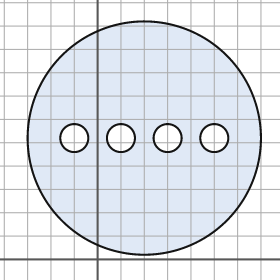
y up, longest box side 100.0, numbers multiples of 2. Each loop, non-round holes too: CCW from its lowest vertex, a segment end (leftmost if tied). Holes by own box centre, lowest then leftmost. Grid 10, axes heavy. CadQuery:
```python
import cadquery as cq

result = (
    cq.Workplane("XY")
    .moveTo(20.0, 52.0)
    .circle(50.0)
    .moveTo(-10.0, 52.0)
    .circle(6.0)
    .moveTo(10.0, 52.0)
    .circle(6.0)
    .moveTo(30.0, 52.0)
    .circle(6.0)
    .moveTo(50.0, 52.0)
    .circle(6.0)
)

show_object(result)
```